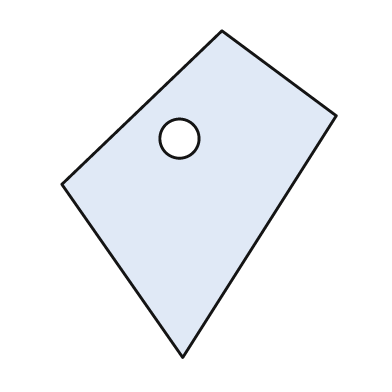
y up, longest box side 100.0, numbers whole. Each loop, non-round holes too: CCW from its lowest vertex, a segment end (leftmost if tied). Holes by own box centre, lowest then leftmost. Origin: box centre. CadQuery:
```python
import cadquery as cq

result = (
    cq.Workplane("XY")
    .moveTo(-5.0, -50.0)
    .lineTo(42.0, 24.0)
    .lineTo(7.0, 50.0)
    .lineTo(-42.0, 3.0)
    .close()
    .moveTo(-6.0, 17.0)
    .circle(6.0)
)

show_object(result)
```